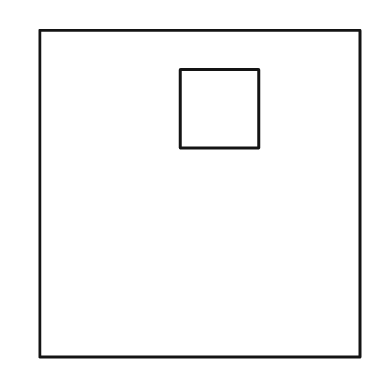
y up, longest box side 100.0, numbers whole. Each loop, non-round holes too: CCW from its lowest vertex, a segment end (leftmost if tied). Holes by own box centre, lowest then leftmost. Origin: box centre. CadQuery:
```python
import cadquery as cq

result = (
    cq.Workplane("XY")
    .moveTo(-49.0, -50.0)
    .lineTo(49.0, -50.0)
    .lineTo(49.0, 50.0)
    .lineTo(-49.0, 50.0)
    .close()
    .moveTo(-6.0, 14.0)
    .lineTo(18.0, 14.0)
    .lineTo(18.0, 38.0)
    .lineTo(-6.0, 38.0)
    .close()
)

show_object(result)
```